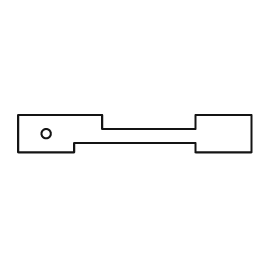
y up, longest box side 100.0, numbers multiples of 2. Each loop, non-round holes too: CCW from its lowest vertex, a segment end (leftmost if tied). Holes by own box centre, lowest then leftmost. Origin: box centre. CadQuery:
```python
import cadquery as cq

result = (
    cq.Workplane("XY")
    .moveTo(-50.0, -8.0)
    .lineTo(-26.0, -8.0)
    .lineTo(-26.0, -4.0)
    .lineTo(26.0, -4.0)
    .lineTo(26.0, -8.0)
    .lineTo(50.0, -8.0)
    .lineTo(50.0, 8.0)
    .lineTo(26.0, 8.0)
    .lineTo(26.0, 2.0)
    .lineTo(-14.0, 2.0)
    .lineTo(-14.0, 8.0)
    .lineTo(-50.0, 8.0)
    .close()
    .moveTo(-38.0, 0.0)
    .circle(2.0)
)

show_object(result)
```